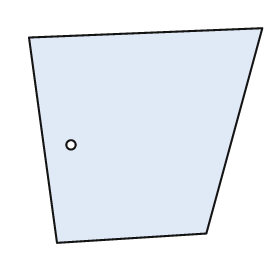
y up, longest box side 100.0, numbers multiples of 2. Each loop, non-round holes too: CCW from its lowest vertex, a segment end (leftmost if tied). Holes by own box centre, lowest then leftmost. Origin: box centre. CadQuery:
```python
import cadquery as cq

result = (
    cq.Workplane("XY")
    .moveTo(-38.0, -46.0)
    .lineTo(26.0, -42.0)
    .lineTo(50.0, 46.0)
    .lineTo(-50.0, 42.0)
    .close()
    .moveTo(-32.0, -4.0)
    .circle(2.0)
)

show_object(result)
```